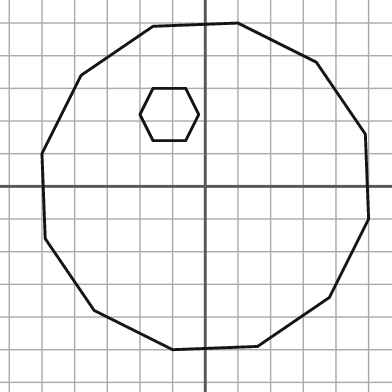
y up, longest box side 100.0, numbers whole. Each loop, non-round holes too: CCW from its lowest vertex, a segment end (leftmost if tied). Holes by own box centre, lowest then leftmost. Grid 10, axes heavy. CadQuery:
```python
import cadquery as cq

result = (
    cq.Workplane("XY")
    .moveTo(-10.0, -50.0)
    .lineTo(16.0, -49.0)
    .lineTo(38.0, -34.0)
    .lineTo(50.0, -10.0)
    .lineTo(49.0, 16.0)
    .lineTo(34.0, 38.0)
    .lineTo(10.0, 50.0)
    .lineTo(-16.0, 49.0)
    .lineTo(-38.0, 34.0)
    .lineTo(-50.0, 10.0)
    .lineTo(-49.0, -16.0)
    .lineTo(-34.0, -38.0)
    .close()
    .moveTo(-16.0, 14.0)
    .lineTo(-6.0, 14.0)
    .lineTo(-2.0, 22.0)
    .lineTo(-6.0, 30.0)
    .lineTo(-16.0, 30.0)
    .lineTo(-20.0, 22.0)
    .close()
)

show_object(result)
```